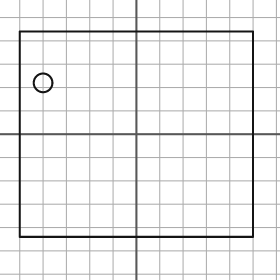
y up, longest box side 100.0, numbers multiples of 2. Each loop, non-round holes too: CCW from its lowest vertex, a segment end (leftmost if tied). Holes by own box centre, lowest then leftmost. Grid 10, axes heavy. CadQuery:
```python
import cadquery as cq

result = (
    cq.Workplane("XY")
    .moveTo(-50.0, -44.0)
    .lineTo(50.0, -44.0)
    .lineTo(50.0, 44.0)
    .lineTo(-50.0, 44.0)
    .close()
    .moveTo(-40.0, 22.0)
    .circle(4.0)
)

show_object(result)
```